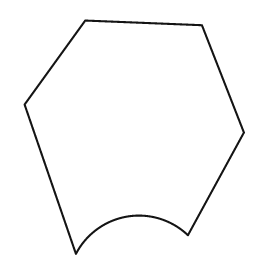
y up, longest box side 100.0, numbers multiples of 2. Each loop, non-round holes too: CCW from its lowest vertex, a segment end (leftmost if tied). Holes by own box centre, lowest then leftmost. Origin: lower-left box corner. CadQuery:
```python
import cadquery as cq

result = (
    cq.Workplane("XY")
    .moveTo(22.0, 0.0)
    .threePointArc((44.0, 16.0), (70.0, 8.0))
    .lineTo(94.0, 52.0)
    .lineTo(76.0, 98.0)
    .lineTo(26.0, 100.0)
    .lineTo(0.0, 64.0)
    .close()
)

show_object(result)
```